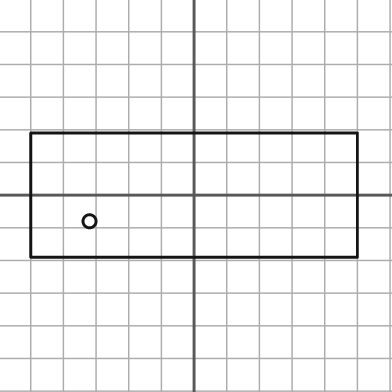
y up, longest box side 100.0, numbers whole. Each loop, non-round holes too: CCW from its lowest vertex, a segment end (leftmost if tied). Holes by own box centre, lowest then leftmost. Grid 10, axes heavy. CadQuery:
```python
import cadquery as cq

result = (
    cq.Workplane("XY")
    .moveTo(-50.0, -19.0)
    .lineTo(50.0, -19.0)
    .lineTo(50.0, 19.0)
    .lineTo(-50.0, 19.0)
    .close()
    .moveTo(-32.0, -8.0)
    .circle(2.0)
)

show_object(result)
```